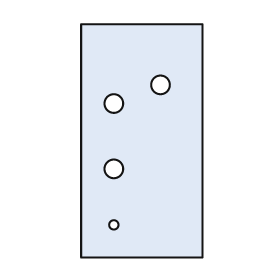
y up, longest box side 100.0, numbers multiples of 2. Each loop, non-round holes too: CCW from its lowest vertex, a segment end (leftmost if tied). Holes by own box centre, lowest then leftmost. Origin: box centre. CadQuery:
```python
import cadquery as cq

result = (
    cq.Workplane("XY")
    .moveTo(-26.0, -50.0)
    .lineTo(26.0, -50.0)
    .lineTo(26.0, 50.0)
    .lineTo(-26.0, 50.0)
    .close()
    .moveTo(-12.0, -36.0)
    .circle(2.0)
    .moveTo(-12.0, -12.0)
    .circle(4.0)
    .moveTo(-12.0, 16.0)
    .circle(4.0)
    .moveTo(8.0, 24.0)
    .circle(4.0)
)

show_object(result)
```